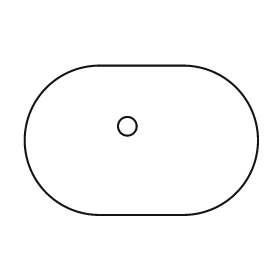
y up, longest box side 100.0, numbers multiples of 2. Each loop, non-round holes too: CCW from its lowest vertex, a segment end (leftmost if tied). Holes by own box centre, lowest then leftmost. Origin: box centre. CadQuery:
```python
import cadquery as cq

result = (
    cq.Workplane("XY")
    .moveTo(-18.0, -32.0)
    .lineTo(18.0, -32.0)
    .threePointArc((50.0, 0.0), (18.0, 32.0))
    .lineTo(-18.0, 32.0)
    .threePointArc((-50.0, 0.0), (-18.0, -32.0))
    .close()
    .moveTo(-6.0, 6.0)
    .circle(4.0)
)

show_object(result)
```